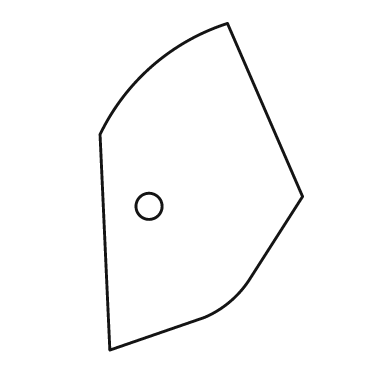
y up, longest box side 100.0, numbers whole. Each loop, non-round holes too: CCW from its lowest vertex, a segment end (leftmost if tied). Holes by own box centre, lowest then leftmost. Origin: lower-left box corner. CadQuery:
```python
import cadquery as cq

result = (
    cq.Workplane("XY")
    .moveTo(3.0, 0.0)
    .lineTo(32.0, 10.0)
    .threePointArc((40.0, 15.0), (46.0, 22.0))
    .lineTo(62.0, 47.0)
    .lineTo(39.0, 100.0)
    .threePointArc((16.0, 87.0), (0.0, 66.0))
    .close()
    .moveTo(15.0, 44.0)
    .circle(4.0)
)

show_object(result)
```